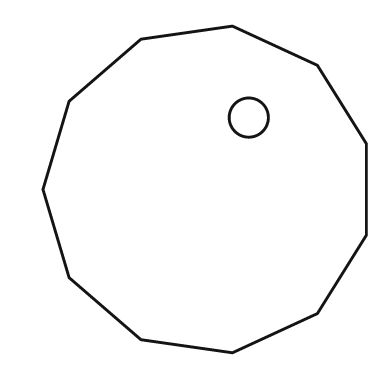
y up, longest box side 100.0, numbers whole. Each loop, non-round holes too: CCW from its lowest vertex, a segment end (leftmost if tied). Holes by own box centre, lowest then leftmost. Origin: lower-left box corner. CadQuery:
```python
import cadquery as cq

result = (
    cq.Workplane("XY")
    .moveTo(58.0, 0.0)
    .lineTo(84.0, 12.0)
    .lineTo(99.0, 36.0)
    .lineTo(99.0, 64.0)
    .lineTo(84.0, 88.0)
    .lineTo(58.0, 100.0)
    .lineTo(30.0, 96.0)
    .lineTo(8.0, 77.0)
    .lineTo(0.0, 50.0)
    .lineTo(8.0, 23.0)
    .lineTo(30.0, 4.0)
    .close()
    .moveTo(63.0, 72.0)
    .circle(6.0)
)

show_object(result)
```